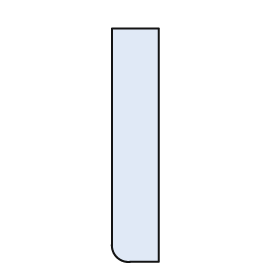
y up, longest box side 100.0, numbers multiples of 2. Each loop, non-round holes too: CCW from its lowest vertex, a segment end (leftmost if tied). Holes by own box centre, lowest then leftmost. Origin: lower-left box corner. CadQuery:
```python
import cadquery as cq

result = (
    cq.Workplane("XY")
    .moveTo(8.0, 0.0)
    .lineTo(20.0, 0.0)
    .lineTo(20.0, 100.0)
    .lineTo(0.0, 100.0)
    .lineTo(0.0, 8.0)
    .threePointArc((2.0, 2.0), (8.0, 0.0))
    .close()
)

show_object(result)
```